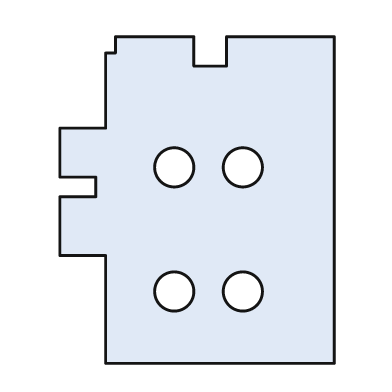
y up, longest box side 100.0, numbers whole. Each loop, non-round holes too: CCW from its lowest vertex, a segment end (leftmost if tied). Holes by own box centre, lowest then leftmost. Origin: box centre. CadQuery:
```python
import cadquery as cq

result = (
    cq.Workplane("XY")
    .moveTo(-28.0, -50.0)
    .lineTo(42.0, -50.0)
    .lineTo(42.0, 50.0)
    .lineTo(9.0, 50.0)
    .lineTo(9.0, 41.0)
    .lineTo(-1.0, 41.0)
    .lineTo(-1.0, 50.0)
    .lineTo(-25.0, 50.0)
    .lineTo(-25.0, 45.0)
    .lineTo(-28.0, 45.0)
    .lineTo(-28.0, 22.0)
    .lineTo(-42.0, 22.0)
    .lineTo(-42.0, 7.0)
    .lineTo(-31.0, 7.0)
    .lineTo(-31.0, 1.0)
    .lineTo(-42.0, 1.0)
    .lineTo(-42.0, -17.0)
    .lineTo(-28.0, -17.0)
    .close()
    .moveTo(-7.0, -28.0)
    .circle(6.0)
    .moveTo(14.0, -28.0)
    .circle(6.0)
    .moveTo(-7.0, 10.0)
    .circle(6.0)
    .moveTo(14.0, 10.0)
    .circle(6.0)
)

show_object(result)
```